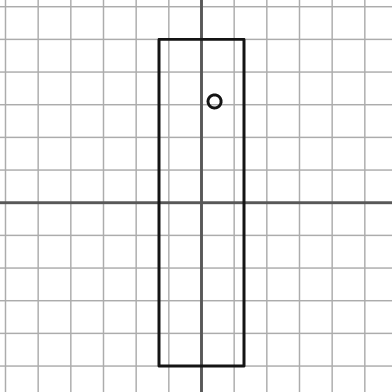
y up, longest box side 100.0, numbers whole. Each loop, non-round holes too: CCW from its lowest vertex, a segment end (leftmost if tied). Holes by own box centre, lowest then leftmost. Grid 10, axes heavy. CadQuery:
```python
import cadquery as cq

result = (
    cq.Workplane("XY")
    .moveTo(-13.0, -50.0)
    .lineTo(13.0, -50.0)
    .lineTo(13.0, 50.0)
    .lineTo(-13.0, 50.0)
    .close()
    .moveTo(4.0, 31.0)
    .circle(2.0)
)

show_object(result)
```